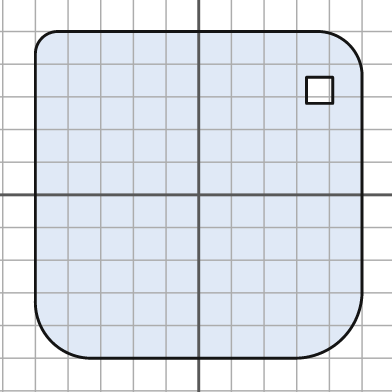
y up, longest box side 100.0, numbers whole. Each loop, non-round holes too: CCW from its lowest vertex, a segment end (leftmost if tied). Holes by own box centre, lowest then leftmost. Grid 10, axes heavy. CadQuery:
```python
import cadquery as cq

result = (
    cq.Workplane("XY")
    .moveTo(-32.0, -50.0)
    .lineTo(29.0, -50.0)
    .threePointArc((44.0, -44.0), (50.0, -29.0))
    .lineTo(50.0, 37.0)
    .threePointArc((46.0, 46.0), (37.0, 50.0))
    .lineTo(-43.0, 50.0)
    .threePointArc((-48.0, 48.0), (-50.0, 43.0))
    .lineTo(-50.0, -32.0)
    .threePointArc((-45.0, -45.0), (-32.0, -50.0))
    .close()
    .moveTo(33.0, 28.0)
    .lineTo(41.0, 28.0)
    .lineTo(41.0, 36.0)
    .lineTo(33.0, 36.0)
    .close()
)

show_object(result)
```